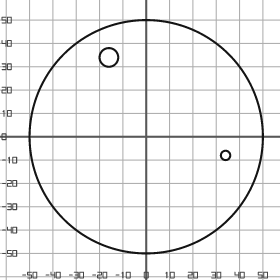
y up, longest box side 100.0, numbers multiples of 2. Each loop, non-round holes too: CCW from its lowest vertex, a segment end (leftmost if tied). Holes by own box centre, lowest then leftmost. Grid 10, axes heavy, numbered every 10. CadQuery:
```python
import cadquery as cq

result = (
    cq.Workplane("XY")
    .moveTo(0.0, 0.0)
    .circle(50.0)
    .moveTo(34.0, -8.0)
    .circle(2.0)
    .moveTo(-16.0, 34.0)
    .circle(4.0)
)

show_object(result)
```